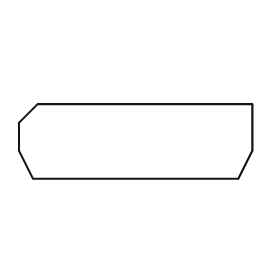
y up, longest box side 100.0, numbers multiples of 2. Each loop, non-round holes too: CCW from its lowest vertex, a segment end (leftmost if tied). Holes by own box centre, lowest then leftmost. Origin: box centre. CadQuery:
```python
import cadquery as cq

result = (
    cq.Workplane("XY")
    .moveTo(-44.0, -16.0)
    .lineTo(44.0, -16.0)
    .lineTo(50.0, -4.0)
    .lineTo(50.0, 16.0)
    .lineTo(-42.0, 16.0)
    .lineTo(-50.0, 8.0)
    .lineTo(-50.0, -4.0)
    .close()
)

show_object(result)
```